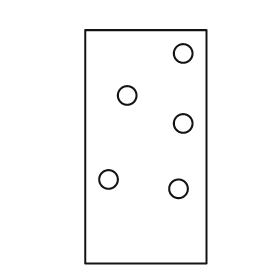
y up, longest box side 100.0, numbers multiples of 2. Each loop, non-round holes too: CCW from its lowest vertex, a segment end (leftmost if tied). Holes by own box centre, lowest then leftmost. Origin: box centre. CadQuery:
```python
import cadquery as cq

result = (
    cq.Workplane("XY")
    .moveTo(-26.0, -50.0)
    .lineTo(26.0, -50.0)
    .lineTo(26.0, 50.0)
    .lineTo(-26.0, 50.0)
    .close()
    .moveTo(14.0, -18.0)
    .circle(4.0)
    .moveTo(-16.0, -14.0)
    .circle(4.0)
    .moveTo(16.0, 10.0)
    .circle(4.0)
    .moveTo(-8.0, 22.0)
    .circle(4.0)
    .moveTo(16.0, 40.0)
    .circle(4.0)
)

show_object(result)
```